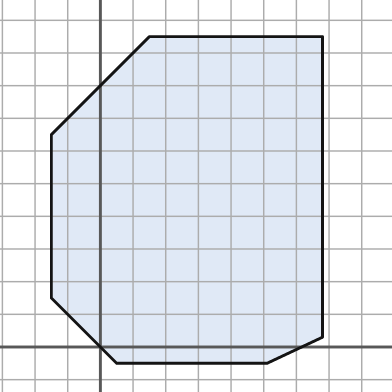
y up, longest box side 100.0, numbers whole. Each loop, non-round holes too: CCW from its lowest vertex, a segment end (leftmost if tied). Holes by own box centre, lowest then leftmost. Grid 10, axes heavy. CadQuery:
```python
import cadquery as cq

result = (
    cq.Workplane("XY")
    .moveTo(5.0, -5.0)
    .lineTo(51.0, -5.0)
    .lineTo(68.0, 3.0)
    .lineTo(68.0, 95.0)
    .lineTo(15.0, 95.0)
    .lineTo(-15.0, 65.0)
    .lineTo(-15.0, 15.0)
    .close()
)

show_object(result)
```